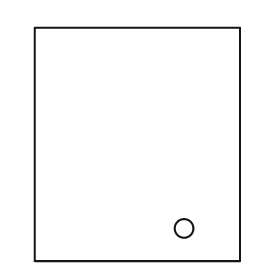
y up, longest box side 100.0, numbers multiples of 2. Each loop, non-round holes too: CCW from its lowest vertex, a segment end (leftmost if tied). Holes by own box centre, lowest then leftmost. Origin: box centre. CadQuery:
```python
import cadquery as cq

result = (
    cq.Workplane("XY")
    .moveTo(-44.0, -50.0)
    .lineTo(44.0, -50.0)
    .lineTo(44.0, 50.0)
    .lineTo(-44.0, 50.0)
    .close()
    .moveTo(20.0, -36.0)
    .circle(4.0)
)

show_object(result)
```